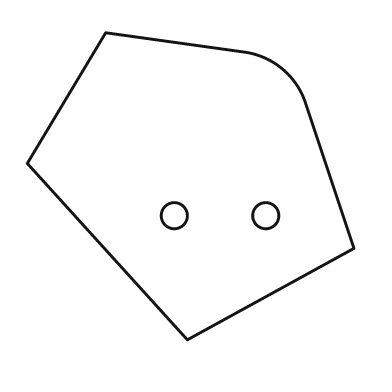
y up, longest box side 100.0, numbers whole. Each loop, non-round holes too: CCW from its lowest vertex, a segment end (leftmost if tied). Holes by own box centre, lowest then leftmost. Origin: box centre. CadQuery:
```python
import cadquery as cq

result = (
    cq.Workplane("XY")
    .moveTo(-1.0, -47.0)
    .lineTo(50.0, -19.0)
    .lineTo(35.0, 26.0)
    .threePointArc((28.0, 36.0), (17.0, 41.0))
    .lineTo(-26.0, 47.0)
    .lineTo(-50.0, 7.0)
    .close()
    .moveTo(-5.0, -9.0)
    .circle(4.0)
    .moveTo(23.0, -9.0)
    .circle(4.0)
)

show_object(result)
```